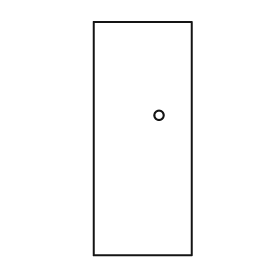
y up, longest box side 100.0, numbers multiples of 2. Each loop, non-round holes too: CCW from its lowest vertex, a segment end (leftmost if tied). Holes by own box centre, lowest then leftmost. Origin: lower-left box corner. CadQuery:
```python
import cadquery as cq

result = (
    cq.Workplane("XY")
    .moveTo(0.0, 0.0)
    .lineTo(42.0, 0.0)
    .lineTo(42.0, 100.0)
    .lineTo(0.0, 100.0)
    .close()
    .moveTo(28.0, 60.0)
    .circle(2.0)
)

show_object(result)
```